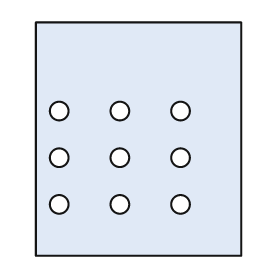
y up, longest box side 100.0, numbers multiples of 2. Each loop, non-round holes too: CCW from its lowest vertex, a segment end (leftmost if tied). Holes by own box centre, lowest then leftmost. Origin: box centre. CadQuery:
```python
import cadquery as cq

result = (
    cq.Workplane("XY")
    .moveTo(-44.0, -50.0)
    .lineTo(44.0, -50.0)
    .lineTo(44.0, 50.0)
    .lineTo(-44.0, 50.0)
    .close()
    .moveTo(-34.0, -28.0)
    .circle(4.0)
    .moveTo(-8.0, -28.0)
    .circle(4.0)
    .moveTo(18.0, -28.0)
    .circle(4.0)
    .moveTo(-34.0, -8.0)
    .circle(4.0)
    .moveTo(-8.0, -8.0)
    .circle(4.0)
    .moveTo(18.0, -8.0)
    .circle(4.0)
    .moveTo(-34.0, 12.0)
    .circle(4.0)
    .moveTo(-8.0, 12.0)
    .circle(4.0)
    .moveTo(18.0, 12.0)
    .circle(4.0)
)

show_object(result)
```